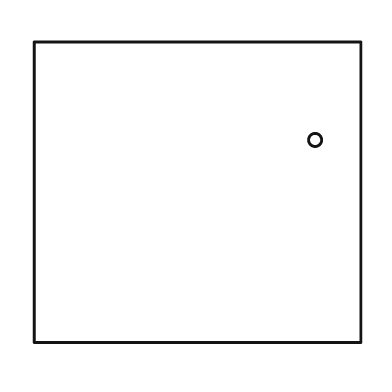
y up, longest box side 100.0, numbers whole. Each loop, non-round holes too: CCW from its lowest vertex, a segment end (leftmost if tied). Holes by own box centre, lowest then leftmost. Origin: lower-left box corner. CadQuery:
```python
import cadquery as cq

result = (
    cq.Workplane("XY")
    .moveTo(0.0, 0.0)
    .lineTo(100.0, 0.0)
    .lineTo(100.0, 92.0)
    .lineTo(0.0, 92.0)
    .close()
    .moveTo(86.0, 62.0)
    .circle(2.0)
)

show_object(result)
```